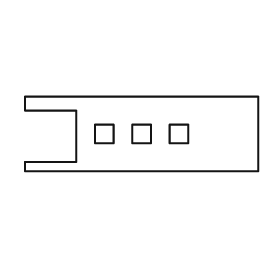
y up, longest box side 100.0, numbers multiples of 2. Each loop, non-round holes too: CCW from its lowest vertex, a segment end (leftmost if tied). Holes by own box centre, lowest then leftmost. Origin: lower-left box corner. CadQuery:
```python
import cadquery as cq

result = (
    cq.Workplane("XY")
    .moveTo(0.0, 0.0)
    .lineTo(100.0, 0.0)
    .lineTo(100.0, 32.0)
    .lineTo(0.0, 32.0)
    .lineTo(0.0, 26.0)
    .lineTo(22.0, 26.0)
    .lineTo(22.0, 4.0)
    .lineTo(0.0, 4.0)
    .close()
    .moveTo(30.0, 12.0)
    .lineTo(38.0, 12.0)
    .lineTo(38.0, 20.0)
    .lineTo(30.0, 20.0)
    .close()
    .moveTo(46.0, 12.0)
    .lineTo(54.0, 12.0)
    .lineTo(54.0, 20.0)
    .lineTo(46.0, 20.0)
    .close()
    .moveTo(62.0, 12.0)
    .lineTo(70.0, 12.0)
    .lineTo(70.0, 20.0)
    .lineTo(62.0, 20.0)
    .close()
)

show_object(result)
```